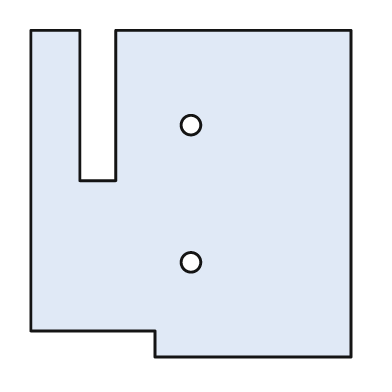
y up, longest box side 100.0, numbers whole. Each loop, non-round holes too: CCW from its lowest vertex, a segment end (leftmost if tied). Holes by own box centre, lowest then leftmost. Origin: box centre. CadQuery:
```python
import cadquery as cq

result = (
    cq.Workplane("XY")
    .moveTo(-11.0, -50.0)
    .lineTo(49.0, -50.0)
    .lineTo(49.0, 50.0)
    .lineTo(-23.0, 50.0)
    .lineTo(-23.0, 4.0)
    .lineTo(-34.0, 4.0)
    .lineTo(-34.0, 50.0)
    .lineTo(-49.0, 50.0)
    .lineTo(-49.0, -42.0)
    .lineTo(-11.0, -42.0)
    .close()
    .moveTo(0.0, -21.0)
    .circle(3.0)
    .moveTo(0.0, 21.0)
    .circle(3.0)
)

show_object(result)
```